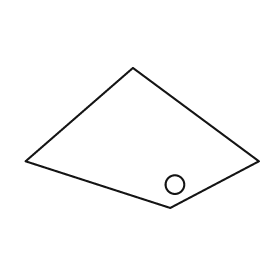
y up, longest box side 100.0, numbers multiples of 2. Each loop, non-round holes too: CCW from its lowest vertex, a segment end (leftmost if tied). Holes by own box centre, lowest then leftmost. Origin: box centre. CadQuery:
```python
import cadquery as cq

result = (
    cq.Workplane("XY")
    .moveTo(12.0, -30.0)
    .lineTo(50.0, -10.0)
    .lineTo(-4.0, 30.0)
    .lineTo(-50.0, -10.0)
    .close()
    .moveTo(14.0, -20.0)
    .circle(4.0)
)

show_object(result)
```